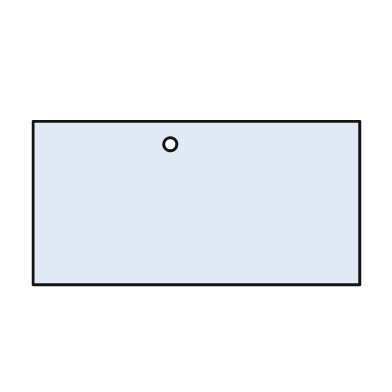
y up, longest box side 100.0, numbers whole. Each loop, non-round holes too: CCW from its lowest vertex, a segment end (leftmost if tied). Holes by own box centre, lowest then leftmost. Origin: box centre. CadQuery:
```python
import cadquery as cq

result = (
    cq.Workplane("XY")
    .moveTo(-50.0, -25.0)
    .lineTo(50.0, -25.0)
    .lineTo(50.0, 25.0)
    .lineTo(-50.0, 25.0)
    .close()
    .moveTo(-8.0, 18.0)
    .circle(2.0)
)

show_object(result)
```